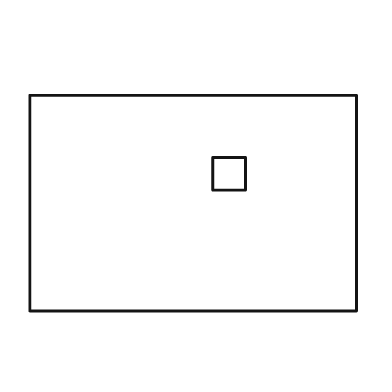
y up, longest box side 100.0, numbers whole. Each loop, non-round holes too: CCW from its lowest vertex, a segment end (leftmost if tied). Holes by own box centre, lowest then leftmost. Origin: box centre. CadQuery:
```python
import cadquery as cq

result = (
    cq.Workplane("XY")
    .moveTo(-50.0, -33.0)
    .lineTo(50.0, -33.0)
    .lineTo(50.0, 33.0)
    .lineTo(-50.0, 33.0)
    .close()
    .moveTo(6.0, 4.0)
    .lineTo(16.0, 4.0)
    .lineTo(16.0, 14.0)
    .lineTo(6.0, 14.0)
    .close()
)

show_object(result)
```